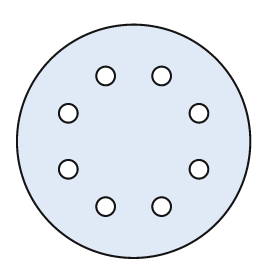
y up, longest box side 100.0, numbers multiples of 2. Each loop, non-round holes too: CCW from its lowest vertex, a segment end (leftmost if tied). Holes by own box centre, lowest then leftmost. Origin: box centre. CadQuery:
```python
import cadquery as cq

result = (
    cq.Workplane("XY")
    .moveTo(0.0, 0.0)
    .circle(50.0)
    .moveTo(-12.0, -28.0)
    .circle(4.0)
    .moveTo(12.0, -28.0)
    .circle(4.0)
    .moveTo(-28.0, -12.0)
    .circle(4.0)
    .moveTo(28.0, -12.0)
    .circle(4.0)
    .moveTo(-28.0, 12.0)
    .circle(4.0)
    .moveTo(28.0, 12.0)
    .circle(4.0)
    .moveTo(-12.0, 28.0)
    .circle(4.0)
    .moveTo(12.0, 28.0)
    .circle(4.0)
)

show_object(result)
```